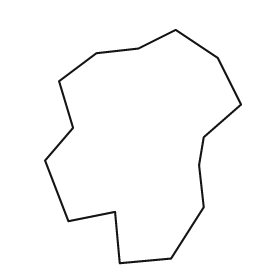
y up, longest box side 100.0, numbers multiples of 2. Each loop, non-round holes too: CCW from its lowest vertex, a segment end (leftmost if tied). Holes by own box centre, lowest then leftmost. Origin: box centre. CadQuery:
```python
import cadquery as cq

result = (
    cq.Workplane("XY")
    .moveTo(-10.0, -50.0)
    .lineTo(12.0, -48.0)
    .lineTo(26.0, -26.0)
    .lineTo(24.0, -8.0)
    .lineTo(26.0, 4.0)
    .lineTo(42.0, 18.0)
    .lineTo(32.0, 38.0)
    .lineTo(14.0, 50.0)
    .lineTo(-2.0, 42.0)
    .lineTo(-20.0, 40.0)
    .lineTo(-36.0, 28.0)
    .lineTo(-30.0, 8.0)
    .lineTo(-42.0, -6.0)
    .lineTo(-32.0, -32.0)
    .lineTo(-12.0, -28.0)
    .close()
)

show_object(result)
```